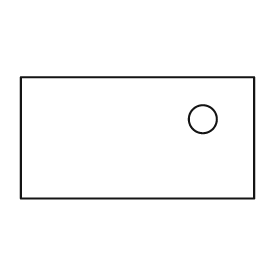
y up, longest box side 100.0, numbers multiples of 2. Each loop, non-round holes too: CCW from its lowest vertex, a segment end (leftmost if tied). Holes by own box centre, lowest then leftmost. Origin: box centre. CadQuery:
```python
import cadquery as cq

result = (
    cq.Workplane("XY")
    .moveTo(-50.0, -26.0)
    .lineTo(50.0, -26.0)
    .lineTo(50.0, 26.0)
    .lineTo(-50.0, 26.0)
    .close()
    .moveTo(28.0, 8.0)
    .circle(6.0)
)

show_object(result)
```